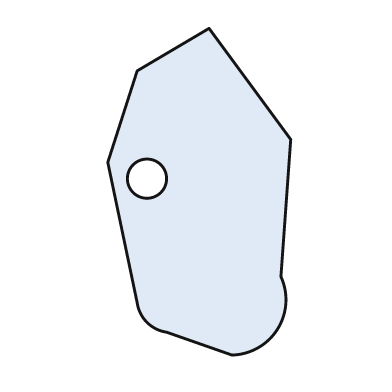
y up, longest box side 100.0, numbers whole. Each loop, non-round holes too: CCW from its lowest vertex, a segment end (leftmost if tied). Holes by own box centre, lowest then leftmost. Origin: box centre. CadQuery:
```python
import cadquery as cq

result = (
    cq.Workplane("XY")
    .moveTo(10.0, -50.0)
    .threePointArc((24.0, -42.0), (25.0, -26.0))
    .lineTo(28.0, 16.0)
    .lineTo(3.0, 50.0)
    .lineTo(-19.0, 37.0)
    .lineTo(-28.0, 9.0)
    .lineTo(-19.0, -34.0)
    .threePointArc((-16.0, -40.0), (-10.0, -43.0))
    .close()
    .moveTo(-16.0, 4.0)
    .circle(6.0)
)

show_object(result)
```